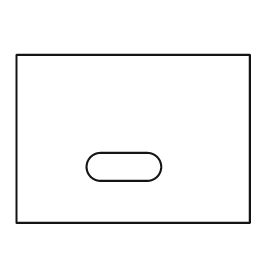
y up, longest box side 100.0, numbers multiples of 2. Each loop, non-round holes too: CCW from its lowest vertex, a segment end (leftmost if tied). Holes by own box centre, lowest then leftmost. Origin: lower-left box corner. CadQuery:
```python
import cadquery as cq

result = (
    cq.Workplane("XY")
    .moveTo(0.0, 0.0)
    .lineTo(100.0, 0.0)
    .lineTo(100.0, 72.0)
    .lineTo(0.0, 72.0)
    .close()
    .moveTo(36.0, 18.0)
    .lineTo(56.0, 18.0)
    .threePointArc((62.0, 24.0), (56.0, 30.0))
    .lineTo(36.0, 30.0)
    .threePointArc((30.0, 24.0), (36.0, 18.0))
    .close()
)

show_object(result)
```